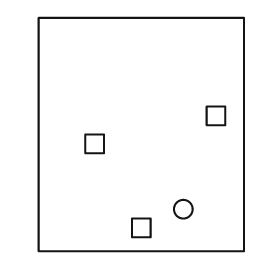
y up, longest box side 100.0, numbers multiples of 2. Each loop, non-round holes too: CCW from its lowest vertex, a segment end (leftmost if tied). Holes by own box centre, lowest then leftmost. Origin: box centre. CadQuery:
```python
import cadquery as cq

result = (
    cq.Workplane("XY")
    .moveTo(-44.0, -50.0)
    .lineTo(44.0, -50.0)
    .lineTo(44.0, 50.0)
    .lineTo(-44.0, 50.0)
    .close()
    .moveTo(-4.0, -44.0)
    .lineTo(4.0, -44.0)
    .lineTo(4.0, -36.0)
    .lineTo(-4.0, -36.0)
    .close()
    .moveTo(18.0, -32.0)
    .circle(4.0)
    .moveTo(-24.0, -8.0)
    .lineTo(-16.0, -8.0)
    .lineTo(-16.0, 0.0)
    .lineTo(-24.0, 0.0)
    .close()
    .moveTo(28.0, 4.0)
    .lineTo(36.0, 4.0)
    .lineTo(36.0, 12.0)
    .lineTo(28.0, 12.0)
    .close()
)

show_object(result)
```